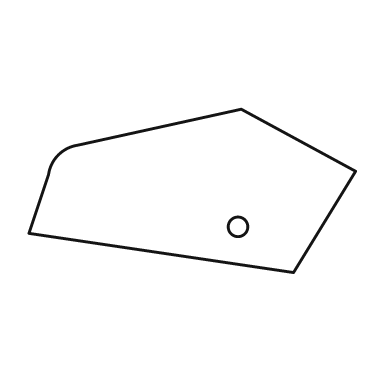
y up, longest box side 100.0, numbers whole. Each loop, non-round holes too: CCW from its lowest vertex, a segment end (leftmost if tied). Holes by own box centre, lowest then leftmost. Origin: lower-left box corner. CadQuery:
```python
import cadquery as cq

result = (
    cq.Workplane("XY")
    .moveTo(81.0, 0.0)
    .lineTo(100.0, 31.0)
    .lineTo(65.0, 50.0)
    .lineTo(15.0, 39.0)
    .threePointArc((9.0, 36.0), (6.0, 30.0))
    .lineTo(0.0, 12.0)
    .close()
    .moveTo(64.0, 14.0)
    .circle(3.0)
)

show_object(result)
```